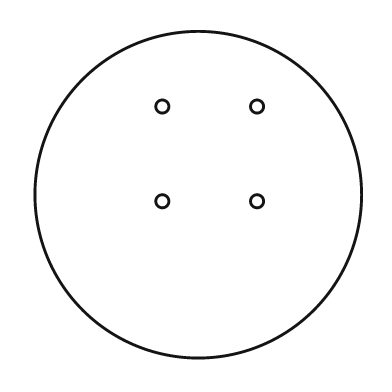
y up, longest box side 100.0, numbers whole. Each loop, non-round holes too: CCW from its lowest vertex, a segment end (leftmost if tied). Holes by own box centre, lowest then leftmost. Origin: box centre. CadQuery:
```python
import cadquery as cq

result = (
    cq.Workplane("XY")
    .moveTo(0.0, 0.0)
    .circle(50.0)
    .moveTo(-11.0, -2.0)
    .circle(2.0)
    .moveTo(18.0, -2.0)
    .circle(2.0)
    .moveTo(-11.0, 27.0)
    .circle(2.0)
    .moveTo(18.0, 27.0)
    .circle(2.0)
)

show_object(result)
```